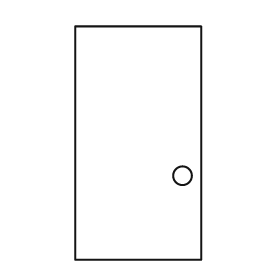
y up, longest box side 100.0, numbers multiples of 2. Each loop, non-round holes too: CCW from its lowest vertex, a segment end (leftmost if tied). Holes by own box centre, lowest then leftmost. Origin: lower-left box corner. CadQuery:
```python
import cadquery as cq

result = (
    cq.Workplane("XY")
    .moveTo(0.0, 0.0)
    .lineTo(54.0, 0.0)
    .lineTo(54.0, 100.0)
    .lineTo(0.0, 100.0)
    .close()
    .moveTo(46.0, 36.0)
    .circle(4.0)
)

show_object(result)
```